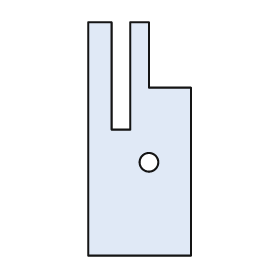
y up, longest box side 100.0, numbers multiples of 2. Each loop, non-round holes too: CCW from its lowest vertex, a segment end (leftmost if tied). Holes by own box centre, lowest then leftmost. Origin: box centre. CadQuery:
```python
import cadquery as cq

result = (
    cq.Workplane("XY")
    .moveTo(-22.0, -50.0)
    .lineTo(22.0, -50.0)
    .lineTo(22.0, 22.0)
    .lineTo(4.0, 22.0)
    .lineTo(4.0, 50.0)
    .lineTo(-4.0, 50.0)
    .lineTo(-4.0, 4.0)
    .lineTo(-12.0, 4.0)
    .lineTo(-12.0, 50.0)
    .lineTo(-22.0, 50.0)
    .close()
    .moveTo(4.0, -10.0)
    .circle(4.0)
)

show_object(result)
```